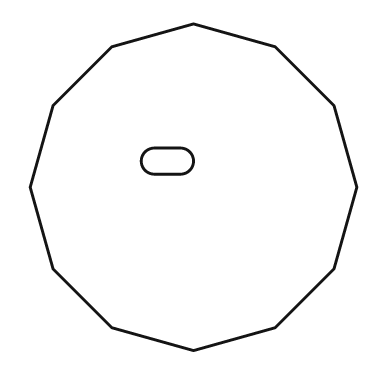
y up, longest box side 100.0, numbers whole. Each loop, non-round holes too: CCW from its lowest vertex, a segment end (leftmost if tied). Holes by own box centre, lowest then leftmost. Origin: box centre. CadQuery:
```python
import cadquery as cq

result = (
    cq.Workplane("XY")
    .moveTo(0.0, -50.0)
    .lineTo(25.0, -43.0)
    .lineTo(43.0, -25.0)
    .lineTo(50.0, 0.0)
    .lineTo(43.0, 25.0)
    .lineTo(25.0, 43.0)
    .lineTo(0.0, 50.0)
    .lineTo(-25.0, 43.0)
    .lineTo(-43.0, 25.0)
    .lineTo(-50.0, 0.0)
    .lineTo(-43.0, -25.0)
    .lineTo(-25.0, -43.0)
    .close()
    .moveTo(-12.0, 4.0)
    .lineTo(-4.0, 4.0)
    .threePointArc((0.0, 8.0), (-4.0, 12.0))
    .lineTo(-12.0, 12.0)
    .threePointArc((-16.0, 8.0), (-12.0, 4.0))
    .close()
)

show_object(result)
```